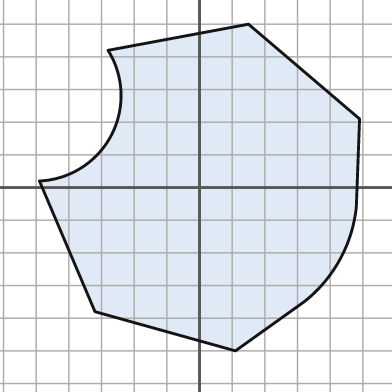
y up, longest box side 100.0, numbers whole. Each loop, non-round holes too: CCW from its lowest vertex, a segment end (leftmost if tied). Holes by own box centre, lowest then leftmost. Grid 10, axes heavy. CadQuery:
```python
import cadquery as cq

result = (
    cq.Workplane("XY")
    .moveTo(11.0, -50.0)
    .lineTo(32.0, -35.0)
    .threePointArc((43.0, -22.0), (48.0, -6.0))
    .lineTo(49.0, 21.0)
    .lineTo(15.0, 50.0)
    .lineTo(-28.0, 42.0)
    .threePointArc((-27.0, 16.0), (-49.0, 2.0))
    .lineTo(-32.0, -38.0)
    .close()
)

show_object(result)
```